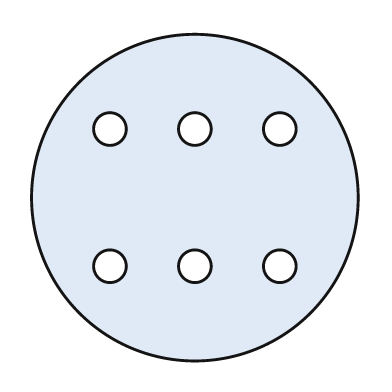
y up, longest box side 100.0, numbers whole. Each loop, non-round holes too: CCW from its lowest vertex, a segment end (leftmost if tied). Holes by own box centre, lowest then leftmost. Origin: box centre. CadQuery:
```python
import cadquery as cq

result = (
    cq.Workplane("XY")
    .moveTo(0.0, 0.0)
    .circle(50.0)
    .moveTo(-26.0, -21.0)
    .circle(5.0)
    .moveTo(0.0, -21.0)
    .circle(5.0)
    .moveTo(26.0, -21.0)
    .circle(5.0)
    .moveTo(-26.0, 21.0)
    .circle(5.0)
    .moveTo(0.0, 21.0)
    .circle(5.0)
    .moveTo(26.0, 21.0)
    .circle(5.0)
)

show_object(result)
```